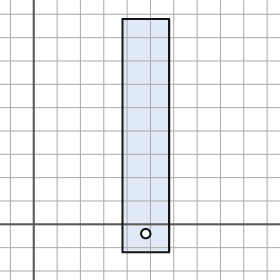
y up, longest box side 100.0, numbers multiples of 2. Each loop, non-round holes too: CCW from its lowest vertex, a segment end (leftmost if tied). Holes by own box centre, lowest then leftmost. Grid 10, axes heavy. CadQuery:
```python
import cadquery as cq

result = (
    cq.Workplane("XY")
    .moveTo(38.0, -12.0)
    .lineTo(58.0, -12.0)
    .lineTo(58.0, 88.0)
    .lineTo(38.0, 88.0)
    .close()
    .moveTo(48.0, -4.0)
    .circle(2.0)
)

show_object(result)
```